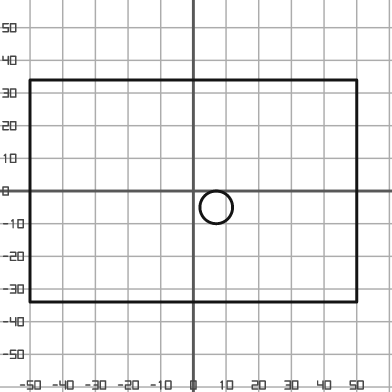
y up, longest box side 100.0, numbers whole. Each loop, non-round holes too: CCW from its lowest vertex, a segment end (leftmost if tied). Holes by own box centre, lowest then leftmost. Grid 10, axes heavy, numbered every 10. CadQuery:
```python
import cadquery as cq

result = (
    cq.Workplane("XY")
    .moveTo(-50.0, -34.0)
    .lineTo(50.0, -34.0)
    .lineTo(50.0, 34.0)
    .lineTo(-50.0, 34.0)
    .close()
    .moveTo(7.0, -5.0)
    .circle(5.0)
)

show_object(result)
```